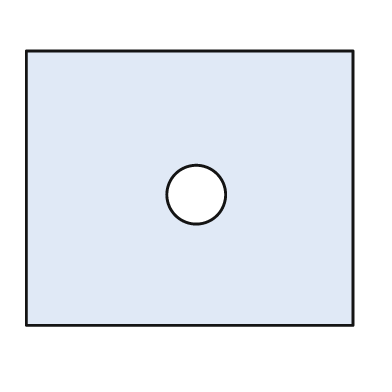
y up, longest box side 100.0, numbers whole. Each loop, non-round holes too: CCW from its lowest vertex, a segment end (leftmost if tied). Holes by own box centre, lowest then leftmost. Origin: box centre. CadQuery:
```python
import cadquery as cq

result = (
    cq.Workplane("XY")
    .moveTo(-50.0, -42.0)
    .lineTo(50.0, -42.0)
    .lineTo(50.0, 42.0)
    .lineTo(-50.0, 42.0)
    .close()
    .moveTo(2.0, -2.0)
    .circle(9.0)
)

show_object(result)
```